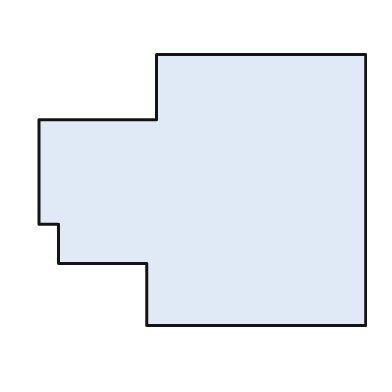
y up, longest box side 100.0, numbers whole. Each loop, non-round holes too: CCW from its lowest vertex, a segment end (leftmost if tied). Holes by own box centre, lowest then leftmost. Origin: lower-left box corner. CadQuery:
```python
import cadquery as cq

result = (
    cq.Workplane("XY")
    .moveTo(33.0, 0.0)
    .lineTo(100.0, 0.0)
    .lineTo(100.0, 83.0)
    .lineTo(36.0, 83.0)
    .lineTo(36.0, 63.0)
    .lineTo(0.0, 63.0)
    .lineTo(0.0, 31.0)
    .lineTo(6.0, 31.0)
    .lineTo(6.0, 19.0)
    .lineTo(33.0, 19.0)
    .close()
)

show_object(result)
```